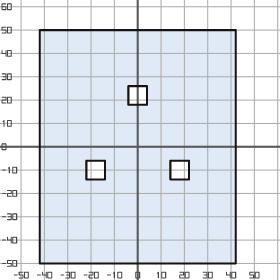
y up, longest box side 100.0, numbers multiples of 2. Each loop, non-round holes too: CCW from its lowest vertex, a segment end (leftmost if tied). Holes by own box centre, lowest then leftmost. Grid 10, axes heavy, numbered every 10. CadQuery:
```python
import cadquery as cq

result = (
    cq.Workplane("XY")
    .moveTo(-42.0, -50.0)
    .lineTo(42.0, -50.0)
    .lineTo(42.0, 50.0)
    .lineTo(-42.0, 50.0)
    .close()
    .moveTo(-22.0, -14.0)
    .lineTo(-14.0, -14.0)
    .lineTo(-14.0, -6.0)
    .lineTo(-22.0, -6.0)
    .close()
    .moveTo(14.0, -14.0)
    .lineTo(22.0, -14.0)
    .lineTo(22.0, -6.0)
    .lineTo(14.0, -6.0)
    .close()
    .moveTo(-4.0, 18.0)
    .lineTo(4.0, 18.0)
    .lineTo(4.0, 26.0)
    .lineTo(-4.0, 26.0)
    .close()
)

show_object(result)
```